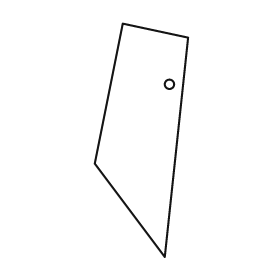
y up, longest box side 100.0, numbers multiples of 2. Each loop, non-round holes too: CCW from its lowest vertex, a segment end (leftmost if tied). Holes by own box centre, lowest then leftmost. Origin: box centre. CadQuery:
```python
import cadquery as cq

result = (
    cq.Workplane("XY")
    .moveTo(10.0, -50.0)
    .lineTo(20.0, 44.0)
    .lineTo(-8.0, 50.0)
    .lineTo(-20.0, -10.0)
    .close()
    .moveTo(12.0, 24.0)
    .circle(2.0)
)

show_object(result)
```